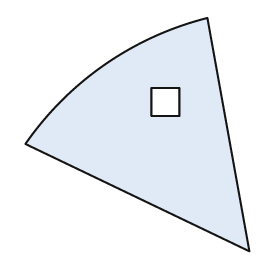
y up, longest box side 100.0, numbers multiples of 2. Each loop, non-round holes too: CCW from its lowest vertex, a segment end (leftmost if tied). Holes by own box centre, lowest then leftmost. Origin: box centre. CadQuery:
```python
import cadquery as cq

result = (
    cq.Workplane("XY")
    .moveTo(48.0, -50.0)
    .lineTo(30.0, 50.0)
    .threePointArc((-14.0, 30.0), (-48.0, -4.0))
    .close()
    .moveTo(6.0, 8.0)
    .lineTo(18.0, 8.0)
    .lineTo(18.0, 20.0)
    .lineTo(6.0, 20.0)
    .close()
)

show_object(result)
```